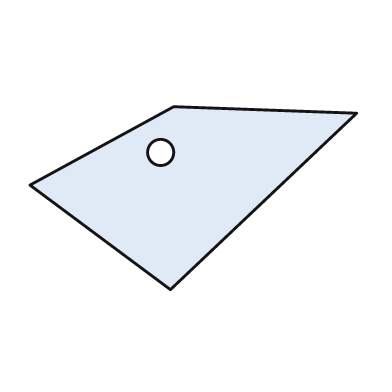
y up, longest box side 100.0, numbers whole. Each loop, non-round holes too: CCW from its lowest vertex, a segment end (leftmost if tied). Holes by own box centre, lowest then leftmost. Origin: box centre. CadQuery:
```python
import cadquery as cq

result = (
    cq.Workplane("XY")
    .moveTo(-7.0, -28.0)
    .lineTo(50.0, 26.0)
    .lineTo(-6.0, 28.0)
    .lineTo(-50.0, 4.0)
    .close()
    .moveTo(-10.0, 14.0)
    .circle(4.0)
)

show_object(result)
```